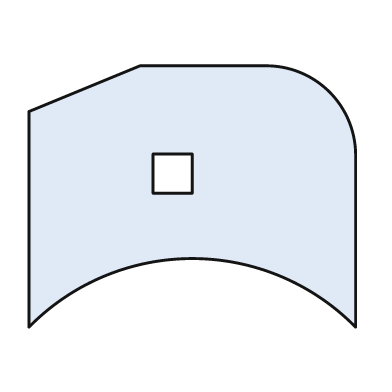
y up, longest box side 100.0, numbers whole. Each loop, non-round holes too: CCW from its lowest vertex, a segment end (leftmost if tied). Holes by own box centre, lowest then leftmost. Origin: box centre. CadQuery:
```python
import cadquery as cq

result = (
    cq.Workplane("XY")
    .moveTo(-50.0, -40.0)
    .threePointArc((0.0, -19.0), (50.0, -40.0))
    .lineTo(50.0, 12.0)
    .threePointArc((42.0, 32.0), (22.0, 40.0))
    .lineTo(-16.0, 40.0)
    .lineTo(-50.0, 26.0)
    .close()
    .moveTo(-12.0, 1.0)
    .lineTo(0.0, 1.0)
    .lineTo(0.0, 13.0)
    .lineTo(-12.0, 13.0)
    .close()
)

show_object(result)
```